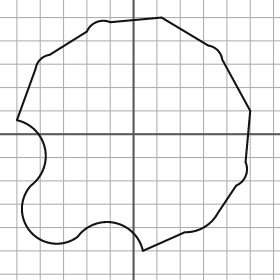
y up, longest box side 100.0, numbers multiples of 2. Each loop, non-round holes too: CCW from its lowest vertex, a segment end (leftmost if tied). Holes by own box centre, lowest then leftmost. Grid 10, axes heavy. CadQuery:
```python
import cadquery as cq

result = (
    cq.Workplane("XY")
    .moveTo(4.0, -50.0)
    .lineTo(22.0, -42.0)
    .threePointArc((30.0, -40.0), (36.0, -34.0))
    .lineTo(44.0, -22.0)
    .threePointArc((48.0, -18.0), (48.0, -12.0))
    .lineTo(50.0, 10.0)
    .lineTo(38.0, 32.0)
    .threePointArc((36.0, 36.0), (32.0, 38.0))
    .lineTo(12.0, 50.0)
    .lineTo(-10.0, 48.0)
    .threePointArc((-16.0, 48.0), (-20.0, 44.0))
    .lineTo(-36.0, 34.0)
    .threePointArc((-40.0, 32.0), (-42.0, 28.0))
    .lineTo(-50.0, 6.0)
    .threePointArc((-38.0, -6.0), (-44.0, -22.0))
    .threePointArc((-44.0, -42.0), (-24.0, -44.0))
    .threePointArc((-8.0, -38.0), (4.0, -50.0))
    .close()
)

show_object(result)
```